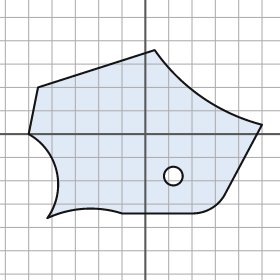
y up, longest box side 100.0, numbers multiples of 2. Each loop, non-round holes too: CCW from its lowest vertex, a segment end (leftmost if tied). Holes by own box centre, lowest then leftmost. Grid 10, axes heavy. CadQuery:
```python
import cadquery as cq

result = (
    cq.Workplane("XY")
    .moveTo(-42.0, -36.0)
    .threePointArc((-26.0, -32.0), (-10.0, -34.0))
    .lineTo(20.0, -34.0)
    .threePointArc((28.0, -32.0), (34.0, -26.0))
    .lineTo(50.0, 4.0)
    .threePointArc((24.0, 16.0), (4.0, 36.0))
    .lineTo(-46.0, 20.0)
    .lineTo(-50.0, 0.0)
    .threePointArc((-38.0, -16.0), (-42.0, -36.0))
    .close()
    .moveTo(12.0, -18.0)
    .circle(4.0)
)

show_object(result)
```